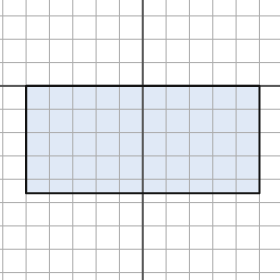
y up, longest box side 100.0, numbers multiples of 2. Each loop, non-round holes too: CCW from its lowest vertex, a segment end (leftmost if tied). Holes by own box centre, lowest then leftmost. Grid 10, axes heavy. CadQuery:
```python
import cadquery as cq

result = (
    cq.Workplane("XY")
    .moveTo(-50.0, -46.0)
    .lineTo(50.0, -46.0)
    .lineTo(50.0, 0.0)
    .lineTo(-50.0, 0.0)
    .close()
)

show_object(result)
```